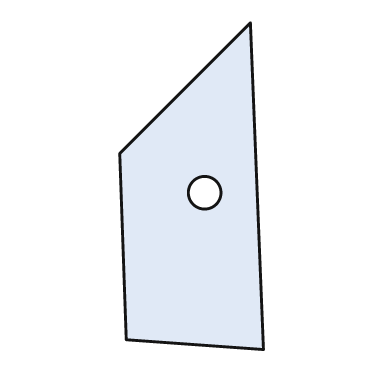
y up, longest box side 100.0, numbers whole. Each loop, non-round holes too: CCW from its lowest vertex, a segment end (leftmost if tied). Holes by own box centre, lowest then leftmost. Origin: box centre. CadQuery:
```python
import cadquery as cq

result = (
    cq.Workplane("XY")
    .moveTo(22.0, -50.0)
    .lineTo(18.0, 50.0)
    .lineTo(-22.0, 10.0)
    .lineTo(-20.0, -47.0)
    .close()
    .moveTo(4.0, -2.0)
    .circle(5.0)
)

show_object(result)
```